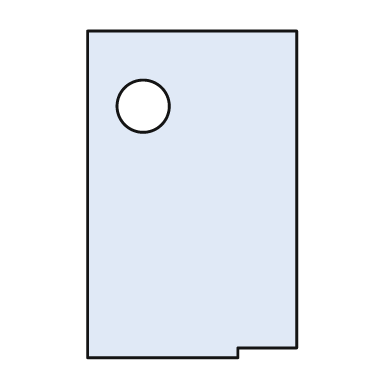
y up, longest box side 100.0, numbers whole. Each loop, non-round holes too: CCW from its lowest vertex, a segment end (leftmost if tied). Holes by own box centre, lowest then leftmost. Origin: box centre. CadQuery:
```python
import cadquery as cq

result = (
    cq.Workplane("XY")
    .moveTo(-32.0, -50.0)
    .lineTo(14.0, -50.0)
    .lineTo(14.0, -47.0)
    .lineTo(32.0, -47.0)
    .lineTo(32.0, 50.0)
    .lineTo(-32.0, 50.0)
    .close()
    .moveTo(-15.0, 27.0)
    .circle(8.0)
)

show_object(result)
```